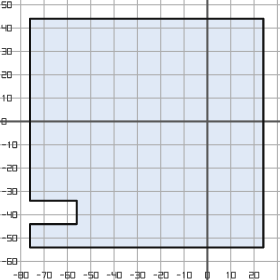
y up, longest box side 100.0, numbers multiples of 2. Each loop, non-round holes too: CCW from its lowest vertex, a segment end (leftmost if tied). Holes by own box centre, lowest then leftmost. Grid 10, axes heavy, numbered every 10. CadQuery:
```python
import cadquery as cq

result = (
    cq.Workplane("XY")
    .moveTo(-76.0, -54.0)
    .lineTo(24.0, -54.0)
    .lineTo(24.0, 44.0)
    .lineTo(-76.0, 44.0)
    .lineTo(-76.0, -34.0)
    .lineTo(-56.0, -34.0)
    .lineTo(-56.0, -44.0)
    .lineTo(-76.0, -44.0)
    .close()
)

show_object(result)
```